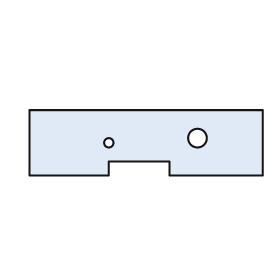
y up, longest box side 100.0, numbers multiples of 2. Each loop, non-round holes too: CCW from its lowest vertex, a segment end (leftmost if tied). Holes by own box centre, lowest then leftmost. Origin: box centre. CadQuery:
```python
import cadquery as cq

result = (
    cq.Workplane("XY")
    .moveTo(-50.0, -14.0)
    .lineTo(-16.0, -14.0)
    .lineTo(-16.0, -8.0)
    .lineTo(10.0, -8.0)
    .lineTo(10.0, -14.0)
    .lineTo(50.0, -14.0)
    .lineTo(50.0, 14.0)
    .lineTo(-50.0, 14.0)
    .close()
    .moveTo(-16.0, 0.0)
    .circle(2.0)
    .moveTo(22.0, 2.0)
    .circle(4.0)
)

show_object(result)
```